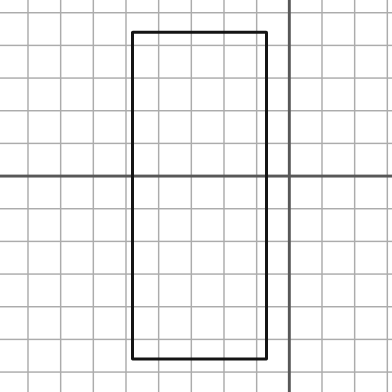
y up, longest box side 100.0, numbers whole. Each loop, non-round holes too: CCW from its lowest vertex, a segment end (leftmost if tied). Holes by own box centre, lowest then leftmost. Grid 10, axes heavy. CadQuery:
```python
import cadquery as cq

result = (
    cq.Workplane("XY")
    .moveTo(-48.0, -56.0)
    .lineTo(-7.0, -56.0)
    .lineTo(-7.0, 44.0)
    .lineTo(-48.0, 44.0)
    .close()
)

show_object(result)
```